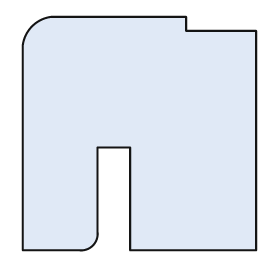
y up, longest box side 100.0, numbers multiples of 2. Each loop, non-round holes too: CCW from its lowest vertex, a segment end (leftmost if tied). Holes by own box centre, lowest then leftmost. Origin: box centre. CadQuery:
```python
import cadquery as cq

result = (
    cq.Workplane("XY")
    .moveTo(-50.0, -50.0)
    .lineTo(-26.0, -50.0)
    .threePointArc((-20.0, -48.0), (-18.0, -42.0))
    .lineTo(-18.0, -6.0)
    .lineTo(-4.0, -6.0)
    .lineTo(-4.0, -50.0)
    .lineTo(50.0, -50.0)
    .lineTo(50.0, 44.0)
    .lineTo(20.0, 44.0)
    .lineTo(20.0, 50.0)
    .lineTo(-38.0, 50.0)
    .threePointArc((-46.0, 46.0), (-50.0, 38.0))
    .close()
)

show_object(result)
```